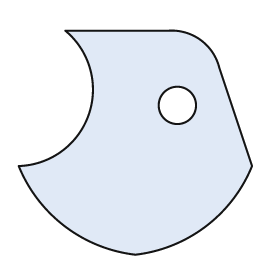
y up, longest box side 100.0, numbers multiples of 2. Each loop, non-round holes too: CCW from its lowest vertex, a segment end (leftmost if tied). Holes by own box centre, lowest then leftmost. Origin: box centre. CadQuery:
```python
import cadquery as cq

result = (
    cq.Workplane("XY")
    .moveTo(0.0, -48.0)
    .threePointArc((30.0, -36.0), (50.0, -10.0))
    .lineTo(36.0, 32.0)
    .threePointArc((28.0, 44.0), (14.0, 48.0))
    .lineTo(-30.0, 48.0)
    .threePointArc((-20.0, 12.0), (-50.0, -10.0))
    .threePointArc((-30.0, -36.0), (0.0, -48.0))
    .close()
    .moveTo(18.0, 16.0)
    .circle(8.0)
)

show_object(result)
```